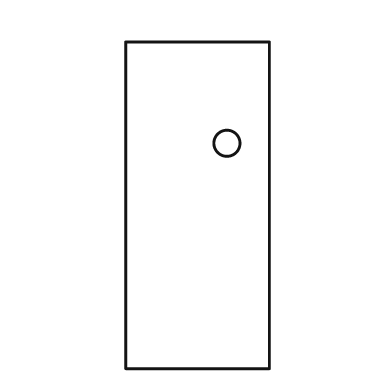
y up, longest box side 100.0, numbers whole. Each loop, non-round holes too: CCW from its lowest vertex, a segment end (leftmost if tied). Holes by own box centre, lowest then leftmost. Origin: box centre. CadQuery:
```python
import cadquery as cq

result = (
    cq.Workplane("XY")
    .moveTo(-22.0, -50.0)
    .lineTo(22.0, -50.0)
    .lineTo(22.0, 50.0)
    .lineTo(-22.0, 50.0)
    .close()
    .moveTo(9.0, 19.0)
    .circle(4.0)
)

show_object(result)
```